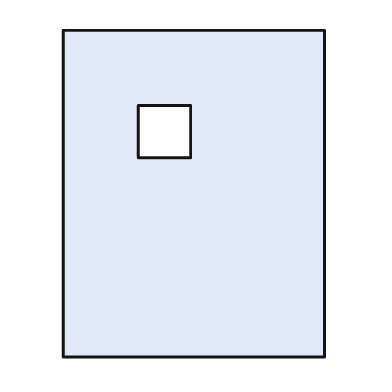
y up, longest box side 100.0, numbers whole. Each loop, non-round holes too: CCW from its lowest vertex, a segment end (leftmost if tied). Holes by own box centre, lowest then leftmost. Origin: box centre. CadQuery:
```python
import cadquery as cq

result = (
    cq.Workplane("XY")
    .moveTo(-40.0, -50.0)
    .lineTo(40.0, -50.0)
    .lineTo(40.0, 50.0)
    .lineTo(-40.0, 50.0)
    .close()
    .moveTo(-17.0, 11.0)
    .lineTo(-1.0, 11.0)
    .lineTo(-1.0, 27.0)
    .lineTo(-17.0, 27.0)
    .close()
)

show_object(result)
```